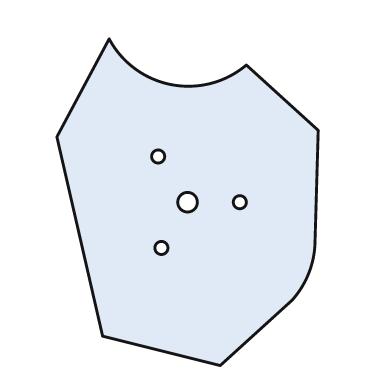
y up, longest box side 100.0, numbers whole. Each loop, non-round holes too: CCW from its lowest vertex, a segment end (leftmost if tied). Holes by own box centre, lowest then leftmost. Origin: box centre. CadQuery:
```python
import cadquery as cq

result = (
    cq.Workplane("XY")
    .moveTo(10.0, -50.0)
    .lineTo(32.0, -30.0)
    .threePointArc((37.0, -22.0), (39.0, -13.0))
    .lineTo(40.0, 22.0)
    .lineTo(18.0, 42.0)
    .threePointArc((-5.0, 36.0), (-24.0, 50.0))
    .lineTo(-40.0, 20.0)
    .lineTo(-26.0, -41.0)
    .close()
    .moveTo(-8.0, -14.0)
    .circle(2.0)
    .moveTo(0.0, 0.0)
    .circle(3.0)
    .moveTo(16.0, 0.0)
    .circle(2.0)
    .moveTo(-9.0, 14.0)
    .circle(2.0)
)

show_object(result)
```